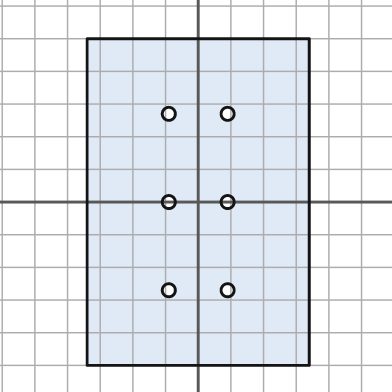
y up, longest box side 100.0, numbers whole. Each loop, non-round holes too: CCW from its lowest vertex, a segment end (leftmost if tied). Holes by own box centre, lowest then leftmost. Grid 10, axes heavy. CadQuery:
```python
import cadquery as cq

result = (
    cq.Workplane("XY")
    .moveTo(-34.0, -50.0)
    .lineTo(34.0, -50.0)
    .lineTo(34.0, 50.0)
    .lineTo(-34.0, 50.0)
    .close()
    .moveTo(-9.0, -27.0)
    .circle(2.0)
    .moveTo(9.0, -27.0)
    .circle(2.0)
    .moveTo(-9.0, 0.0)
    .circle(2.0)
    .moveTo(9.0, 0.0)
    .circle(2.0)
    .moveTo(-9.0, 27.0)
    .circle(2.0)
    .moveTo(9.0, 27.0)
    .circle(2.0)
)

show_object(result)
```